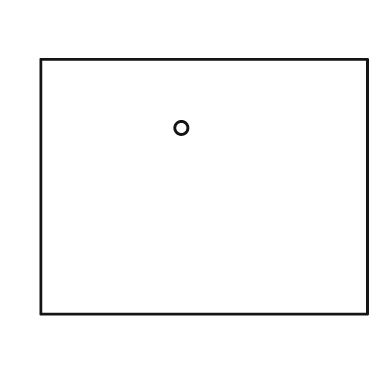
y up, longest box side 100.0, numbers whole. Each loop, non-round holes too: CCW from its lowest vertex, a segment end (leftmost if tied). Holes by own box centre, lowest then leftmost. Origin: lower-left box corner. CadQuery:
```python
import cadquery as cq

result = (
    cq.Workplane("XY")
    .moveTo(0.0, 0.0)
    .lineTo(100.0, 0.0)
    .lineTo(100.0, 78.0)
    .lineTo(0.0, 78.0)
    .close()
    .moveTo(43.0, 57.0)
    .circle(2.0)
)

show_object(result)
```